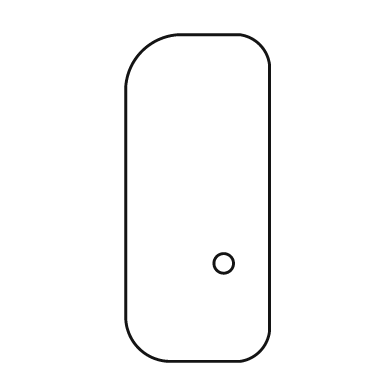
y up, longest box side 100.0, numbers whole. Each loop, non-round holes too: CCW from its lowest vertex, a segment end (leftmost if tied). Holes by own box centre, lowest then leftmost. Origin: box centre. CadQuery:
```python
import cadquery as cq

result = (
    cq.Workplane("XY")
    .moveTo(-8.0, -50.0)
    .lineTo(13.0, -50.0)
    .threePointArc((19.0, -47.0), (22.0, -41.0))
    .lineTo(22.0, 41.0)
    .threePointArc((19.0, 47.0), (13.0, 50.0))
    .lineTo(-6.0, 50.0)
    .threePointArc((-17.0, 45.0), (-22.0, 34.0))
    .lineTo(-22.0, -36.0)
    .threePointArc((-18.0, -46.0), (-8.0, -50.0))
    .close()
    .moveTo(8.0, -20.0)
    .circle(3.0)
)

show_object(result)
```